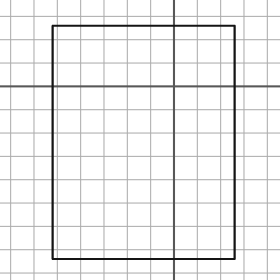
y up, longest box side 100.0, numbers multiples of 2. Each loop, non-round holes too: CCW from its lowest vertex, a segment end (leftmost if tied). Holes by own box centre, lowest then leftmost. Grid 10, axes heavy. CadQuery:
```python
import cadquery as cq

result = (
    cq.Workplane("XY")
    .moveTo(-52.0, -74.0)
    .lineTo(26.0, -74.0)
    .lineTo(26.0, 26.0)
    .lineTo(-52.0, 26.0)
    .close()
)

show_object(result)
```